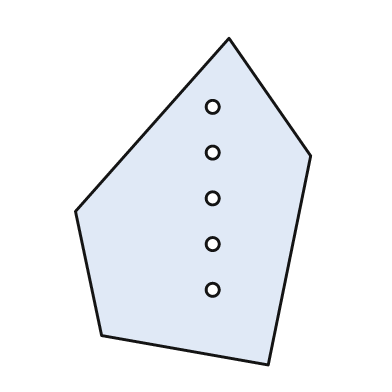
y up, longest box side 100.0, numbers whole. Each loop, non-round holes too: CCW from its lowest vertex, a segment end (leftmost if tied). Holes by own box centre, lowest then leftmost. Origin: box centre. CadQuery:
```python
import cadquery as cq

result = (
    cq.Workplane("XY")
    .moveTo(23.0, -50.0)
    .lineTo(36.0, 14.0)
    .lineTo(11.0, 50.0)
    .lineTo(-36.0, -3.0)
    .lineTo(-28.0, -41.0)
    .close()
    .moveTo(6.0, -27.0)
    .circle(2.0)
    .moveTo(6.0, -13.0)
    .circle(2.0)
    .moveTo(6.0, 1.0)
    .circle(2.0)
    .moveTo(6.0, 15.0)
    .circle(2.0)
    .moveTo(6.0, 29.0)
    .circle(2.0)
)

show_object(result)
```